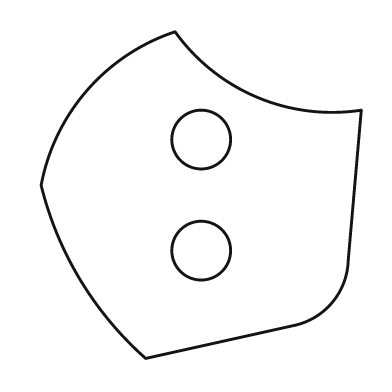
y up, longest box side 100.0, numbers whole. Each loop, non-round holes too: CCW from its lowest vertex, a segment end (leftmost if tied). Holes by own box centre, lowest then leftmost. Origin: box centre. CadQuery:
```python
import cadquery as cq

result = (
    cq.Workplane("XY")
    .moveTo(-17.0, -50.0)
    .lineTo(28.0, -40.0)
    .threePointArc((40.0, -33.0), (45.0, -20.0))
    .lineTo(49.0, 26.0)
    .threePointArc((17.0, 30.0), (-8.0, 50.0))
    .threePointArc((-35.0, 32.0), (-49.0, 3.0))
    .threePointArc((-37.0, -26.0), (-17.0, -50.0))
    .close()
    .moveTo(0.0, -17.0)
    .circle(9.0)
    .moveTo(0.0, 17.0)
    .circle(9.0)
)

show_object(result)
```